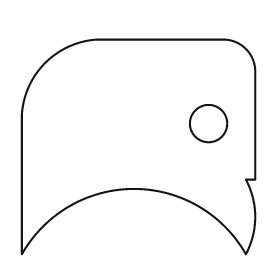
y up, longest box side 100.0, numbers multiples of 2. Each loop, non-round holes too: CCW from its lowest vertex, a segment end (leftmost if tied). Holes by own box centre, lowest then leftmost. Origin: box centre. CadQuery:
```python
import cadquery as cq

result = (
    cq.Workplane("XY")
    .moveTo(-50.0, -46.0)
    .threePointArc((-2.0, -18.0), (46.0, -46.0))
    .threePointArc((50.0, -30.0), (46.0, -14.0))
    .lineTo(50.0, -14.0)
    .lineTo(50.0, 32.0)
    .threePointArc((46.0, 42.0), (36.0, 46.0))
    .lineTo(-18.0, 46.0)
    .threePointArc((-40.0, 36.0), (-50.0, 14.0))
    .close()
    .moveTo(30.0, 10.0)
    .circle(8.0)
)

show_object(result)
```